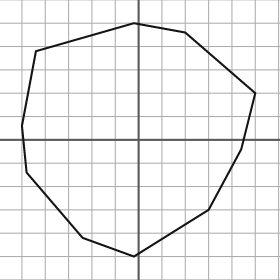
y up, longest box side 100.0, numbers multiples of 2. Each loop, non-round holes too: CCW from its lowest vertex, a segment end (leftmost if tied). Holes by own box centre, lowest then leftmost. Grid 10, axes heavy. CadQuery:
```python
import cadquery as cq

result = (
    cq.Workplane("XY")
    .moveTo(-2.0, -50.0)
    .lineTo(30.0, -30.0)
    .lineTo(44.0, -4.0)
    .lineTo(50.0, 20.0)
    .lineTo(20.0, 46.0)
    .lineTo(-2.0, 50.0)
    .lineTo(-44.0, 38.0)
    .lineTo(-50.0, 6.0)
    .lineTo(-48.0, -14.0)
    .lineTo(-24.0, -42.0)
    .close()
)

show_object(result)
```